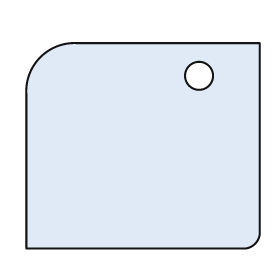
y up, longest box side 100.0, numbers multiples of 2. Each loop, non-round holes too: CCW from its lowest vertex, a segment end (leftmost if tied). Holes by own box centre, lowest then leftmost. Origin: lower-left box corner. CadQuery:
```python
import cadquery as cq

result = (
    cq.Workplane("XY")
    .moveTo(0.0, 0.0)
    .lineTo(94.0, 0.0)
    .threePointArc((98.0, 2.0), (100.0, 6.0))
    .lineTo(100.0, 88.0)
    .lineTo(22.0, 88.0)
    .threePointArc((6.0, 82.0), (0.0, 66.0))
    .close()
    .moveTo(74.0, 74.0)
    .circle(6.0)
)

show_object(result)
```